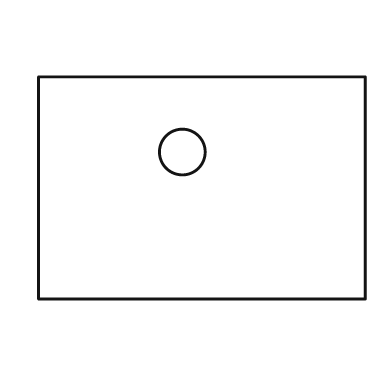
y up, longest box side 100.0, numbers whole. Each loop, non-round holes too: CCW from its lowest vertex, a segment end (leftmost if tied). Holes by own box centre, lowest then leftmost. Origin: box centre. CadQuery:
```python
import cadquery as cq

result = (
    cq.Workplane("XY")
    .moveTo(-50.0, -34.0)
    .lineTo(50.0, -34.0)
    .lineTo(50.0, 34.0)
    .lineTo(-50.0, 34.0)
    .close()
    .moveTo(-6.0, 11.0)
    .circle(7.0)
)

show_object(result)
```